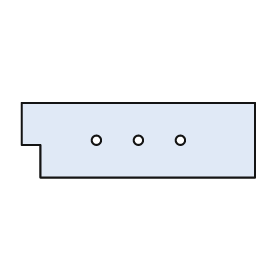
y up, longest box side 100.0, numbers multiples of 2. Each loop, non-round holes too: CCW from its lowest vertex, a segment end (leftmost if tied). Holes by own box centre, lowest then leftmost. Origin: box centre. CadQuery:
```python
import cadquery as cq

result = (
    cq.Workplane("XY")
    .moveTo(-42.0, -16.0)
    .lineTo(50.0, -16.0)
    .lineTo(50.0, 16.0)
    .lineTo(-50.0, 16.0)
    .lineTo(-50.0, -2.0)
    .lineTo(-42.0, -2.0)
    .close()
    .moveTo(-18.0, 0.0)
    .circle(2.0)
    .moveTo(0.0, 0.0)
    .circle(2.0)
    .moveTo(18.0, 0.0)
    .circle(2.0)
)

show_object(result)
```